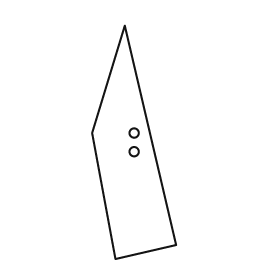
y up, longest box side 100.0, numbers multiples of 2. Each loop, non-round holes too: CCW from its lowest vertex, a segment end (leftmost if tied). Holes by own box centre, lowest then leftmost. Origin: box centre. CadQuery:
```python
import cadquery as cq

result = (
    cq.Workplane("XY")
    .moveTo(-8.0, -50.0)
    .lineTo(18.0, -44.0)
    .lineTo(-4.0, 50.0)
    .lineTo(-18.0, 4.0)
    .close()
    .moveTo(0.0, -4.0)
    .circle(2.0)
    .moveTo(0.0, 4.0)
    .circle(2.0)
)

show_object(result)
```